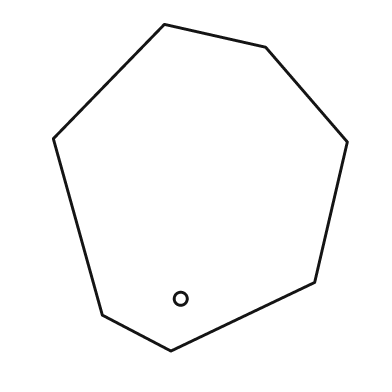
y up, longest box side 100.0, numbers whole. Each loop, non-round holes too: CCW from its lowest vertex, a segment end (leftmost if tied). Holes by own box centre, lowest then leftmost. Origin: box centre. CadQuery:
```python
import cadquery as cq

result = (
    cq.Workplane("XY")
    .moveTo(-9.0, -50.0)
    .lineTo(35.0, -29.0)
    .lineTo(45.0, 14.0)
    .lineTo(20.0, 43.0)
    .lineTo(-11.0, 50.0)
    .lineTo(-45.0, 15.0)
    .lineTo(-30.0, -39.0)
    .close()
    .moveTo(-6.0, -34.0)
    .circle(2.0)
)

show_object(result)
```